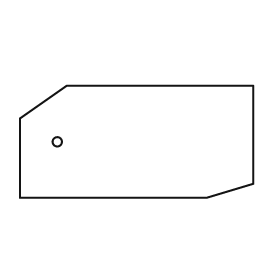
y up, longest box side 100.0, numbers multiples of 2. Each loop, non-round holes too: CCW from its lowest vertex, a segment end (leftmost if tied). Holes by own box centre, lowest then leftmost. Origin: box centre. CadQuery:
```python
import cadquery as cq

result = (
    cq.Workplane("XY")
    .moveTo(-50.0, -24.0)
    .lineTo(30.0, -24.0)
    .lineTo(50.0, -18.0)
    .lineTo(50.0, 24.0)
    .lineTo(-30.0, 24.0)
    .lineTo(-50.0, 10.0)
    .close()
    .moveTo(-34.0, 0.0)
    .circle(2.0)
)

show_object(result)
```